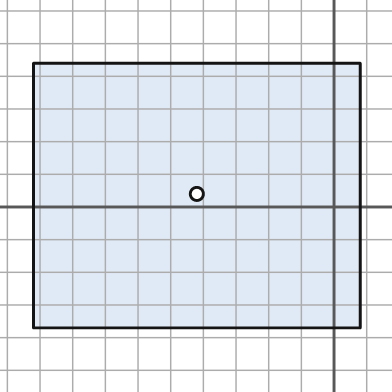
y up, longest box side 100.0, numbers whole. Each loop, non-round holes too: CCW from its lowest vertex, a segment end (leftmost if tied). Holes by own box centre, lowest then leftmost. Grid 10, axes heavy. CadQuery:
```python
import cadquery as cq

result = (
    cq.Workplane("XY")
    .moveTo(-92.0, -37.0)
    .lineTo(8.0, -37.0)
    .lineTo(8.0, 44.0)
    .lineTo(-92.0, 44.0)
    .close()
    .moveTo(-42.0, 4.0)
    .circle(2.0)
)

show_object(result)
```